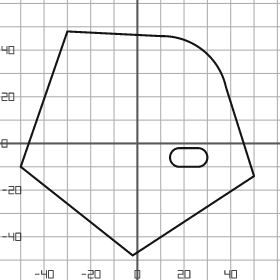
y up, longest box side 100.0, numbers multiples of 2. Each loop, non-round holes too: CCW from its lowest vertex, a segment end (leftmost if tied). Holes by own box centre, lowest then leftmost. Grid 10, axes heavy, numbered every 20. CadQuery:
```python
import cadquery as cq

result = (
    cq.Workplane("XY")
    .moveTo(-2.0, -48.0)
    .lineTo(50.0, -14.0)
    .lineTo(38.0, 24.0)
    .threePointArc((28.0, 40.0), (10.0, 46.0))
    .lineTo(-30.0, 48.0)
    .lineTo(-50.0, -10.0)
    .close()
    .moveTo(18.0, -10.0)
    .lineTo(26.0, -10.0)
    .threePointArc((30.0, -6.0), (26.0, -2.0))
    .lineTo(18.0, -2.0)
    .threePointArc((14.0, -6.0), (18.0, -10.0))
    .close()
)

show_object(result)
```